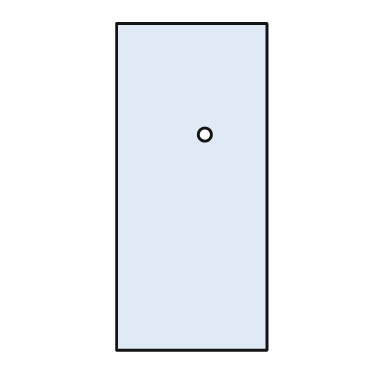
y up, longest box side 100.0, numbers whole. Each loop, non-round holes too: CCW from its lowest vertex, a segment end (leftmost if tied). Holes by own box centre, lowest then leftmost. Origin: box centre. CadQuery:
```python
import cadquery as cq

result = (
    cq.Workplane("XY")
    .moveTo(-23.0, -50.0)
    .lineTo(23.0, -50.0)
    .lineTo(23.0, 50.0)
    .lineTo(-23.0, 50.0)
    .close()
    .moveTo(4.0, 16.0)
    .circle(2.0)
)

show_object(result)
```